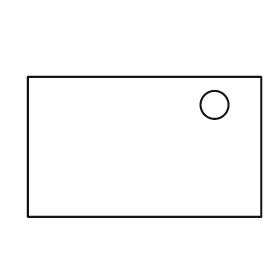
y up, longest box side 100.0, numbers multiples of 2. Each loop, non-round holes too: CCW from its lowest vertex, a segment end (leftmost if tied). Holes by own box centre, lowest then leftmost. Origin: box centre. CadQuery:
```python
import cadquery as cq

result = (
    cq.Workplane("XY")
    .moveTo(-50.0, -30.0)
    .lineTo(50.0, -30.0)
    .lineTo(50.0, 30.0)
    .lineTo(-50.0, 30.0)
    .close()
    .moveTo(30.0, 18.0)
    .circle(6.0)
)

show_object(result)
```